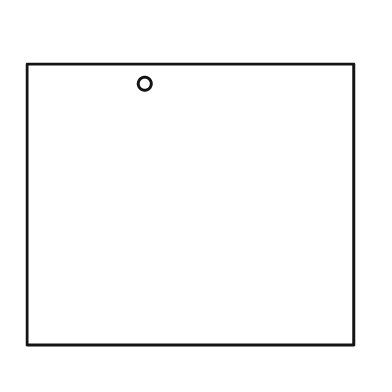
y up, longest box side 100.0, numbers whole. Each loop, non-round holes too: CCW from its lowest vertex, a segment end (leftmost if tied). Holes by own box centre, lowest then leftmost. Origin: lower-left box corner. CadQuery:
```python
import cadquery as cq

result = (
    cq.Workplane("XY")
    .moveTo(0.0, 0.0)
    .lineTo(100.0, 0.0)
    .lineTo(100.0, 86.0)
    .lineTo(0.0, 86.0)
    .close()
    .moveTo(36.0, 80.0)
    .circle(2.0)
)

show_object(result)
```